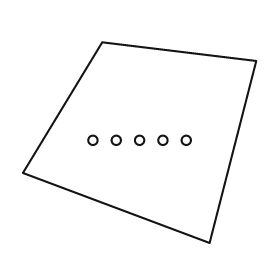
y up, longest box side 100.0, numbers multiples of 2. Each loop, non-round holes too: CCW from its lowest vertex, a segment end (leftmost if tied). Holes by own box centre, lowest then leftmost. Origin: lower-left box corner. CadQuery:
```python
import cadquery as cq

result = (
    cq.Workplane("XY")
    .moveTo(80.0, 0.0)
    .lineTo(100.0, 78.0)
    .lineTo(34.0, 86.0)
    .lineTo(0.0, 30.0)
    .close()
    .moveTo(30.0, 44.0)
    .circle(2.0)
    .moveTo(40.0, 44.0)
    .circle(2.0)
    .moveTo(50.0, 44.0)
    .circle(2.0)
    .moveTo(60.0, 44.0)
    .circle(2.0)
    .moveTo(70.0, 44.0)
    .circle(2.0)
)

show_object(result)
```